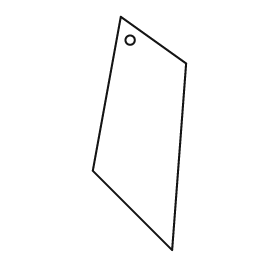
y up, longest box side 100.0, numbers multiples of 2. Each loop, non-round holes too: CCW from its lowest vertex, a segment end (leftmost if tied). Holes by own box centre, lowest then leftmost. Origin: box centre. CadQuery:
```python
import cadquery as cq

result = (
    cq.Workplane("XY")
    .moveTo(14.0, -50.0)
    .lineTo(20.0, 30.0)
    .lineTo(-8.0, 50.0)
    .lineTo(-20.0, -16.0)
    .close()
    .moveTo(-4.0, 40.0)
    .circle(2.0)
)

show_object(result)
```